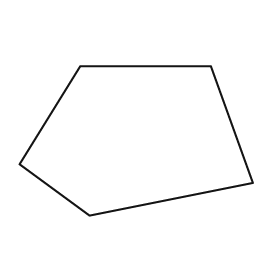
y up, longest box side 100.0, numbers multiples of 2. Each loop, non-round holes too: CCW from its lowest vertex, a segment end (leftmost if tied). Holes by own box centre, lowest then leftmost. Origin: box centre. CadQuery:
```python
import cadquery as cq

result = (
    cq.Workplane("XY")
    .moveTo(-20.0, -32.0)
    .lineTo(50.0, -18.0)
    .lineTo(32.0, 32.0)
    .lineTo(-24.0, 32.0)
    .lineTo(-50.0, -10.0)
    .close()
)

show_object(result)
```